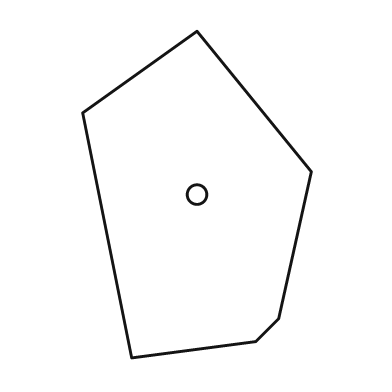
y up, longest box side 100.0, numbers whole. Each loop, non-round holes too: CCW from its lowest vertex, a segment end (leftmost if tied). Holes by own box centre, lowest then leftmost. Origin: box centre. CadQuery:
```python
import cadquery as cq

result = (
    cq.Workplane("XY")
    .moveTo(-20.0, -50.0)
    .lineTo(18.0, -45.0)
    .lineTo(25.0, -38.0)
    .lineTo(35.0, 7.0)
    .lineTo(0.0, 50.0)
    .lineTo(-35.0, 25.0)
    .close()
    .moveTo(0.0, 0.0)
    .circle(3.0)
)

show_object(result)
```